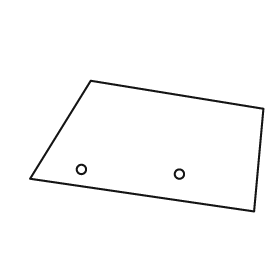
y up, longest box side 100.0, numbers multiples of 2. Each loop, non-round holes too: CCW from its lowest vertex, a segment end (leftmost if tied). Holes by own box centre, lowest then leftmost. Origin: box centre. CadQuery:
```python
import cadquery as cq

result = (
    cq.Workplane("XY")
    .moveTo(46.0, -28.0)
    .lineTo(50.0, 16.0)
    .lineTo(-24.0, 28.0)
    .lineTo(-50.0, -14.0)
    .close()
    .moveTo(14.0, -12.0)
    .circle(2.0)
    .moveTo(-28.0, -10.0)
    .circle(2.0)
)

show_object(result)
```